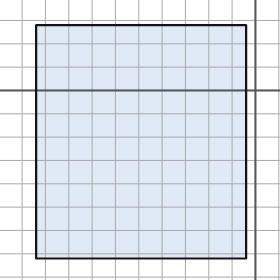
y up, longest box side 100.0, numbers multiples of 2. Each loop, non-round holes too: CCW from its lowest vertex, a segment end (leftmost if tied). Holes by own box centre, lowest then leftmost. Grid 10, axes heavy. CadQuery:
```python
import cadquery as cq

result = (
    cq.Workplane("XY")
    .moveTo(-94.0, -72.0)
    .lineTo(-4.0, -72.0)
    .lineTo(-4.0, 28.0)
    .lineTo(-94.0, 28.0)
    .close()
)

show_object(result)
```